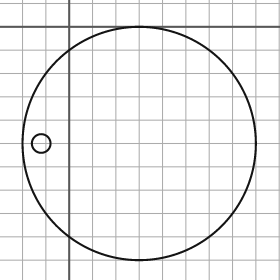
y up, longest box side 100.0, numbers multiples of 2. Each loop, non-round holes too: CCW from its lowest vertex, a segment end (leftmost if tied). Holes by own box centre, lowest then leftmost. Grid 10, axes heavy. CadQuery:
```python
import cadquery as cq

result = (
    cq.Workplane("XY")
    .moveTo(30.0, -50.0)
    .circle(50.0)
    .moveTo(-12.0, -50.0)
    .circle(4.0)
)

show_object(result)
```